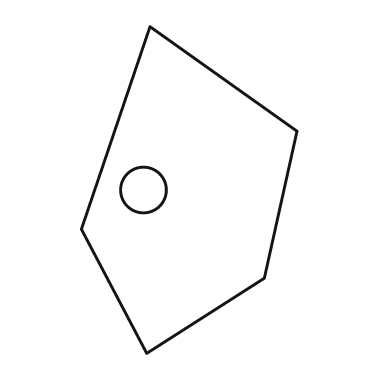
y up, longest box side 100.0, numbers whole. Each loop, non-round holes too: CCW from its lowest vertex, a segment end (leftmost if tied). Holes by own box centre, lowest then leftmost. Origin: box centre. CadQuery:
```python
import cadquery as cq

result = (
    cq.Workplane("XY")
    .moveTo(-13.0, -50.0)
    .lineTo(23.0, -27.0)
    .lineTo(33.0, 18.0)
    .lineTo(-12.0, 50.0)
    .lineTo(-33.0, -12.0)
    .close()
    .moveTo(-14.0, 0.0)
    .circle(7.0)
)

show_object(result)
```